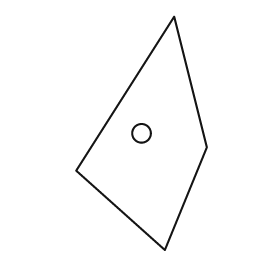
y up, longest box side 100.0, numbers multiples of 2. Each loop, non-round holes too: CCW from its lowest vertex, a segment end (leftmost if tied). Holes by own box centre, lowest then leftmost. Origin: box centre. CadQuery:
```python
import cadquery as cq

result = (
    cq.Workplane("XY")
    .moveTo(10.0, -50.0)
    .lineTo(28.0, -6.0)
    .lineTo(14.0, 50.0)
    .lineTo(-28.0, -16.0)
    .close()
    .moveTo(0.0, 0.0)
    .circle(4.0)
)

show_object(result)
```